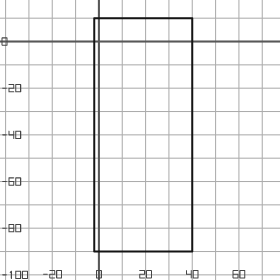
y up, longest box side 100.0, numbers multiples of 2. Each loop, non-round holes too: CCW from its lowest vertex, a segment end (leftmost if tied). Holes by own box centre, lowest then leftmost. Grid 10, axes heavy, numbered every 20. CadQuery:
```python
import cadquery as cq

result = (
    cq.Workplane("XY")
    .moveTo(-2.0, -90.0)
    .lineTo(40.0, -90.0)
    .lineTo(40.0, 10.0)
    .lineTo(-2.0, 10.0)
    .close()
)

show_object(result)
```